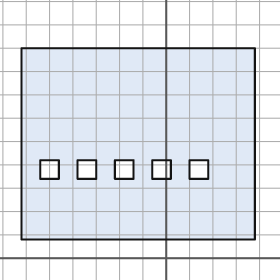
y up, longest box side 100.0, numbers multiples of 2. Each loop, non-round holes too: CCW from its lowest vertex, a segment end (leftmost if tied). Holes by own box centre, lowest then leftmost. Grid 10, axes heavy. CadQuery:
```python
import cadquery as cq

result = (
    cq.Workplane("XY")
    .moveTo(-62.0, 8.0)
    .lineTo(38.0, 8.0)
    .lineTo(38.0, 90.0)
    .lineTo(-62.0, 90.0)
    .close()
    .moveTo(-54.0, 34.0)
    .lineTo(-46.0, 34.0)
    .lineTo(-46.0, 42.0)
    .lineTo(-54.0, 42.0)
    .close()
    .moveTo(-38.0, 34.0)
    .lineTo(-30.0, 34.0)
    .lineTo(-30.0, 42.0)
    .lineTo(-38.0, 42.0)
    .close()
    .moveTo(-22.0, 34.0)
    .lineTo(-14.0, 34.0)
    .lineTo(-14.0, 42.0)
    .lineTo(-22.0, 42.0)
    .close()
    .moveTo(-6.0, 34.0)
    .lineTo(2.0, 34.0)
    .lineTo(2.0, 42.0)
    .lineTo(-6.0, 42.0)
    .close()
    .moveTo(10.0, 34.0)
    .lineTo(18.0, 34.0)
    .lineTo(18.0, 42.0)
    .lineTo(10.0, 42.0)
    .close()
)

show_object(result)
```